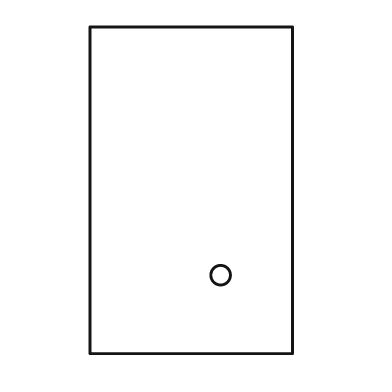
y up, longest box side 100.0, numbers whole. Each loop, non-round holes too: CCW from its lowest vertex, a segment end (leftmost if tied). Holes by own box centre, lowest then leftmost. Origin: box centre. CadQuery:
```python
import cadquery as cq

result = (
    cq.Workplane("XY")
    .moveTo(-31.0, -50.0)
    .lineTo(31.0, -50.0)
    .lineTo(31.0, 50.0)
    .lineTo(-31.0, 50.0)
    .close()
    .moveTo(9.0, -26.0)
    .circle(3.0)
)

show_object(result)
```